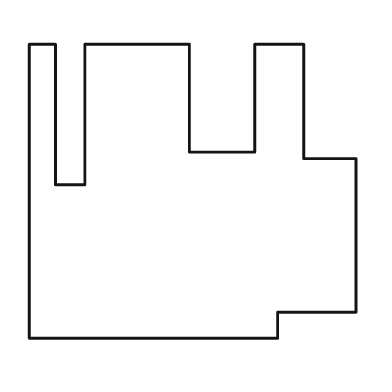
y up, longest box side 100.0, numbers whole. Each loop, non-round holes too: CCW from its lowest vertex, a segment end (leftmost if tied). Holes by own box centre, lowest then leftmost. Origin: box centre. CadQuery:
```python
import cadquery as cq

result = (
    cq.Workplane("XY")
    .moveTo(-50.0, -45.0)
    .lineTo(26.0, -45.0)
    .lineTo(26.0, -37.0)
    .lineTo(50.0, -37.0)
    .lineTo(50.0, 10.0)
    .lineTo(34.0, 10.0)
    .lineTo(34.0, 45.0)
    .lineTo(19.0, 45.0)
    .lineTo(19.0, 12.0)
    .lineTo(-1.0, 12.0)
    .lineTo(-1.0, 45.0)
    .lineTo(-33.0, 45.0)
    .lineTo(-33.0, 2.0)
    .lineTo(-42.0, 2.0)
    .lineTo(-42.0, 45.0)
    .lineTo(-50.0, 45.0)
    .close()
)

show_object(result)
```